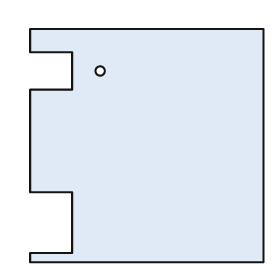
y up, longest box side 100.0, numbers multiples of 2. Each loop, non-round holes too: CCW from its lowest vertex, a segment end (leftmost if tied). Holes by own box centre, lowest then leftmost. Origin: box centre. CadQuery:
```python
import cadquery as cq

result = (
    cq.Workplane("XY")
    .moveTo(-50.0, -50.0)
    .lineTo(50.0, -50.0)
    .lineTo(50.0, 50.0)
    .lineTo(-50.0, 50.0)
    .lineTo(-50.0, 40.0)
    .lineTo(-32.0, 40.0)
    .lineTo(-32.0, 24.0)
    .lineTo(-50.0, 24.0)
    .lineTo(-50.0, -20.0)
    .lineTo(-32.0, -20.0)
    .lineTo(-32.0, -46.0)
    .lineTo(-50.0, -46.0)
    .close()
    .moveTo(-20.0, 32.0)
    .circle(2.0)
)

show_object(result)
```